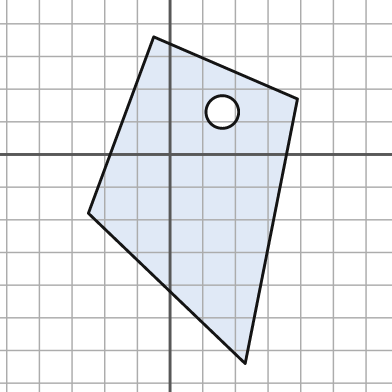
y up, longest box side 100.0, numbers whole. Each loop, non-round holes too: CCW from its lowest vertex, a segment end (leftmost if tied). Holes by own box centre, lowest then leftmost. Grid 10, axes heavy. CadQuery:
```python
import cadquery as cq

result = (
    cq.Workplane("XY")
    .moveTo(23.0, -64.0)
    .lineTo(39.0, 17.0)
    .lineTo(-5.0, 36.0)
    .lineTo(-25.0, -18.0)
    .close()
    .moveTo(16.0, 13.0)
    .circle(5.0)
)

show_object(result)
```